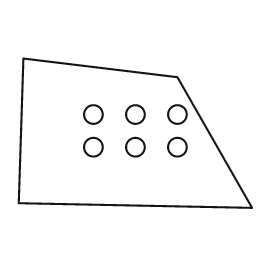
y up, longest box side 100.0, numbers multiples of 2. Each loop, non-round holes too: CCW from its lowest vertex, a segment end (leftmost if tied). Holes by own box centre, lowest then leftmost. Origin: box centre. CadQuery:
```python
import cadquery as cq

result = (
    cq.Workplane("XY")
    .moveTo(50.0, -32.0)
    .lineTo(18.0, 24.0)
    .lineTo(-48.0, 32.0)
    .lineTo(-50.0, -30.0)
    .close()
    .moveTo(-18.0, -6.0)
    .circle(4.0)
    .moveTo(0.0, -6.0)
    .circle(4.0)
    .moveTo(18.0, -6.0)
    .circle(4.0)
    .moveTo(-18.0, 8.0)
    .circle(4.0)
    .moveTo(0.0, 8.0)
    .circle(4.0)
    .moveTo(18.0, 8.0)
    .circle(4.0)
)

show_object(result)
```